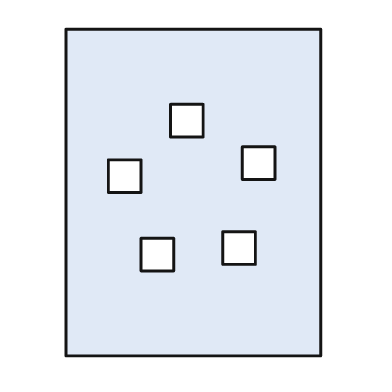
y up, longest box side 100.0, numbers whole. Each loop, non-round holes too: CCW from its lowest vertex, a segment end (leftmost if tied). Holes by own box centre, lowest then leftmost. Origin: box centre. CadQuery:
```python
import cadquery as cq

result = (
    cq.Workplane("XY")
    .moveTo(-39.0, -50.0)
    .lineTo(39.0, -50.0)
    .lineTo(39.0, 50.0)
    .lineTo(-39.0, 50.0)
    .close()
    .moveTo(-16.0, -24.0)
    .lineTo(-6.0, -24.0)
    .lineTo(-6.0, -14.0)
    .lineTo(-16.0, -14.0)
    .close()
    .moveTo(9.0, -22.0)
    .lineTo(19.0, -22.0)
    .lineTo(19.0, -12.0)
    .lineTo(9.0, -12.0)
    .close()
    .moveTo(-26.0, 0.0)
    .lineTo(-16.0, 0.0)
    .lineTo(-16.0, 10.0)
    .lineTo(-26.0, 10.0)
    .close()
    .moveTo(15.0, 4.0)
    .lineTo(25.0, 4.0)
    .lineTo(25.0, 14.0)
    .lineTo(15.0, 14.0)
    .close()
    .moveTo(-7.0, 17.0)
    .lineTo(3.0, 17.0)
    .lineTo(3.0, 27.0)
    .lineTo(-7.0, 27.0)
    .close()
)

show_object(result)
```